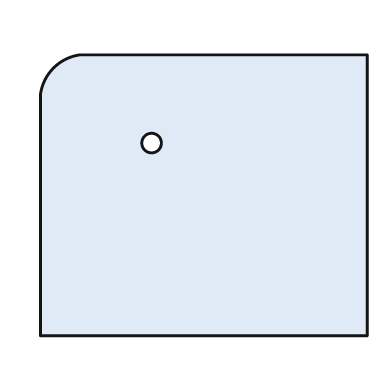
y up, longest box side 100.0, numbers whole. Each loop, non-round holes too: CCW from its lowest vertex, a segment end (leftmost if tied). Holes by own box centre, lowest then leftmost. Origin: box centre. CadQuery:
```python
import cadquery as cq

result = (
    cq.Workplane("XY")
    .moveTo(-50.0, -43.0)
    .lineTo(50.0, -43.0)
    .lineTo(50.0, 43.0)
    .lineTo(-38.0, 43.0)
    .threePointArc((-46.0, 39.0), (-50.0, 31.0))
    .close()
    .moveTo(-16.0, 16.0)
    .circle(3.0)
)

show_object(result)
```